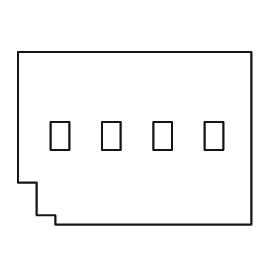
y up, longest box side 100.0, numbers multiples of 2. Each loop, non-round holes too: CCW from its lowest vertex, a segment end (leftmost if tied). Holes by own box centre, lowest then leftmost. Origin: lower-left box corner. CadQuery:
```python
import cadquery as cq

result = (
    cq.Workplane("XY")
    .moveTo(16.0, 0.0)
    .lineTo(100.0, 0.0)
    .lineTo(100.0, 74.0)
    .lineTo(0.0, 74.0)
    .lineTo(0.0, 18.0)
    .lineTo(8.0, 18.0)
    .lineTo(8.0, 4.0)
    .lineTo(16.0, 4.0)
    .close()
    .moveTo(14.0, 32.0)
    .lineTo(22.0, 32.0)
    .lineTo(22.0, 44.0)
    .lineTo(14.0, 44.0)
    .close()
    .moveTo(36.0, 32.0)
    .lineTo(44.0, 32.0)
    .lineTo(44.0, 44.0)
    .lineTo(36.0, 44.0)
    .close()
    .moveTo(58.0, 32.0)
    .lineTo(66.0, 32.0)
    .lineTo(66.0, 44.0)
    .lineTo(58.0, 44.0)
    .close()
    .moveTo(80.0, 32.0)
    .lineTo(88.0, 32.0)
    .lineTo(88.0, 44.0)
    .lineTo(80.0, 44.0)
    .close()
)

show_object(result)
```